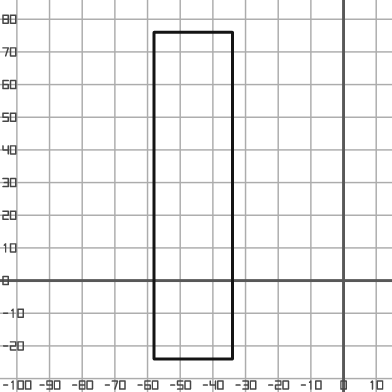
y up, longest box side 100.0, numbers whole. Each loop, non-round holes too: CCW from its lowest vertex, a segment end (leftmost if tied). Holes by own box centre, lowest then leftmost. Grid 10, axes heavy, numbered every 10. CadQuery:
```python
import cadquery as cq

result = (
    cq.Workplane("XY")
    .moveTo(-58.0, -24.0)
    .lineTo(-34.0, -24.0)
    .lineTo(-34.0, 76.0)
    .lineTo(-58.0, 76.0)
    .close()
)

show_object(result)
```